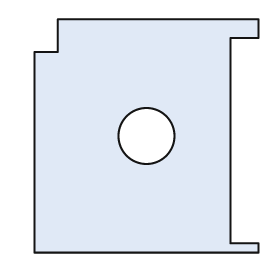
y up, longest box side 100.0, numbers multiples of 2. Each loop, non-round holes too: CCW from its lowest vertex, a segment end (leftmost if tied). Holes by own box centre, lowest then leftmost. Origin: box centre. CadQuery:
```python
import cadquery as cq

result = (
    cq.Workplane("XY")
    .moveTo(-48.0, -50.0)
    .lineTo(48.0, -50.0)
    .lineTo(48.0, -46.0)
    .lineTo(36.0, -46.0)
    .lineTo(36.0, 42.0)
    .lineTo(48.0, 42.0)
    .lineTo(48.0, 50.0)
    .lineTo(-38.0, 50.0)
    .lineTo(-38.0, 36.0)
    .lineTo(-48.0, 36.0)
    .close()
    .moveTo(0.0, 0.0)
    .circle(12.0)
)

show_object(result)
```